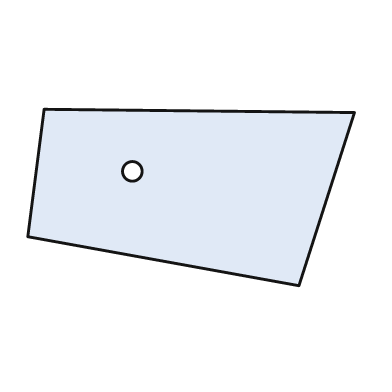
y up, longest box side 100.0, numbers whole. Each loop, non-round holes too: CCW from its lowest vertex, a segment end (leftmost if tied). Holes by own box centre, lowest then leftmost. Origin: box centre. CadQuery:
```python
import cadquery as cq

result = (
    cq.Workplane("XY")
    .moveTo(33.0, -27.0)
    .lineTo(50.0, 26.0)
    .lineTo(-45.0, 27.0)
    .lineTo(-50.0, -12.0)
    .close()
    .moveTo(-18.0, 8.0)
    .circle(3.0)
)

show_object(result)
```